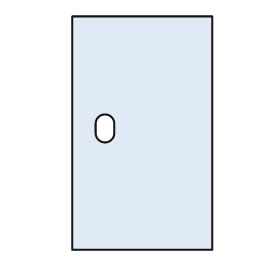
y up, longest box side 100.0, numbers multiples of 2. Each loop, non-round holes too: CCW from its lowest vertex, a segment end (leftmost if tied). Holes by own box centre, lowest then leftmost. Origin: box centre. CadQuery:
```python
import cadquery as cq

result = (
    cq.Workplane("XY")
    .moveTo(-30.0, -50.0)
    .lineTo(30.0, -50.0)
    .lineTo(30.0, 50.0)
    .lineTo(-30.0, 50.0)
    .close()
    .moveTo(-20.0, 0.0)
    .threePointArc((-16.0, -4.0), (-12.0, 0.0))
    .lineTo(-12.0, 4.0)
    .threePointArc((-16.0, 8.0), (-20.0, 4.0))
    .close()
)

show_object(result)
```